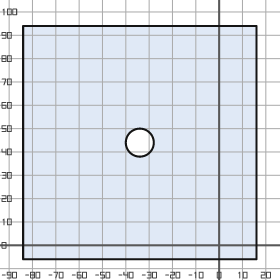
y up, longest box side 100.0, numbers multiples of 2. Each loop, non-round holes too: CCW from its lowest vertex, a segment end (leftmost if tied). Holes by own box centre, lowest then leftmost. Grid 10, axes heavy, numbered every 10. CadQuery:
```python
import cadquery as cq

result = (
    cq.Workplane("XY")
    .moveTo(-84.0, -6.0)
    .lineTo(16.0, -6.0)
    .lineTo(16.0, 94.0)
    .lineTo(-84.0, 94.0)
    .close()
    .moveTo(-34.0, 44.0)
    .circle(6.0)
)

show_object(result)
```